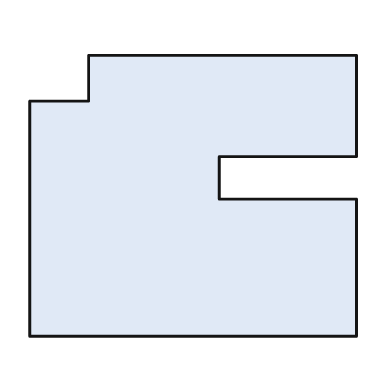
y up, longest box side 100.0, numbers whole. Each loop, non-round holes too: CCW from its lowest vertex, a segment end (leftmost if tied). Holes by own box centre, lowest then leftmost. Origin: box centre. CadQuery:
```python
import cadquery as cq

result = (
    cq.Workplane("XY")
    .moveTo(-50.0, -43.0)
    .lineTo(50.0, -43.0)
    .lineTo(50.0, -1.0)
    .lineTo(8.0, -1.0)
    .lineTo(8.0, 12.0)
    .lineTo(50.0, 12.0)
    .lineTo(50.0, 43.0)
    .lineTo(-32.0, 43.0)
    .lineTo(-32.0, 29.0)
    .lineTo(-50.0, 29.0)
    .close()
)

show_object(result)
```